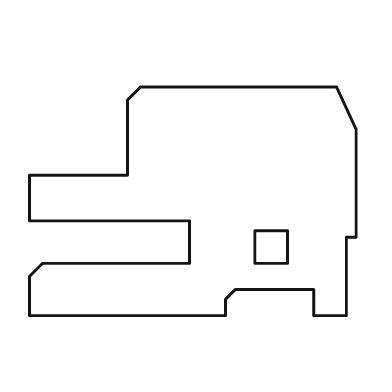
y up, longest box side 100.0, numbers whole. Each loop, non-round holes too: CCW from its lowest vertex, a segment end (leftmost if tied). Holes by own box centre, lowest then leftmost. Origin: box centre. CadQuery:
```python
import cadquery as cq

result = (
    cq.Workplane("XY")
    .moveTo(-50.0, -35.0)
    .lineTo(10.0, -35.0)
    .lineTo(10.0, -30.0)
    .lineTo(13.0, -27.0)
    .lineTo(37.0, -27.0)
    .lineTo(37.0, -35.0)
    .lineTo(47.0, -35.0)
    .lineTo(47.0, -11.0)
    .lineTo(50.0, -11.0)
    .lineTo(50.0, 22.0)
    .lineTo(44.0, 35.0)
    .lineTo(-16.0, 35.0)
    .lineTo(-20.0, 31.0)
    .lineTo(-20.0, 8.0)
    .lineTo(-50.0, 8.0)
    .lineTo(-50.0, -6.0)
    .lineTo(-1.0, -6.0)
    .lineTo(-1.0, -19.0)
    .lineTo(-46.0, -19.0)
    .lineTo(-50.0, -23.0)
    .close()
    .moveTo(19.0, -19.0)
    .lineTo(29.0, -19.0)
    .lineTo(29.0, -9.0)
    .lineTo(19.0, -9.0)
    .close()
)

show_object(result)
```